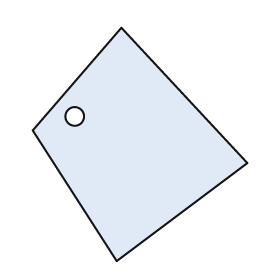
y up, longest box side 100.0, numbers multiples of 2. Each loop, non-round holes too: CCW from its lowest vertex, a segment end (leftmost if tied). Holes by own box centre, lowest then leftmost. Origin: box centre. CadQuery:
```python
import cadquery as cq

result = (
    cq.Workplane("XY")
    .moveTo(-10.0, -50.0)
    .lineTo(46.0, -8.0)
    .lineTo(-8.0, 50.0)
    .lineTo(-46.0, 6.0)
    .close()
    .moveTo(-28.0, 12.0)
    .circle(4.0)
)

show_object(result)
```